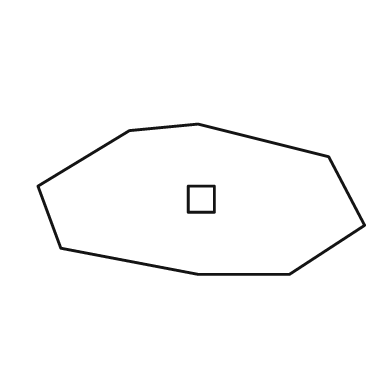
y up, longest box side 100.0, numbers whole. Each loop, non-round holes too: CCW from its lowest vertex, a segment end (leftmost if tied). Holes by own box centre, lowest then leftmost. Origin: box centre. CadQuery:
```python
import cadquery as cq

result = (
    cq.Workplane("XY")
    .moveTo(-1.0, -23.0)
    .lineTo(27.0, -23.0)
    .lineTo(50.0, -8.0)
    .lineTo(39.0, 13.0)
    .lineTo(-1.0, 23.0)
    .lineTo(-22.0, 21.0)
    .lineTo(-50.0, 4.0)
    .lineTo(-43.0, -15.0)
    .close()
    .moveTo(-4.0, -4.0)
    .lineTo(4.0, -4.0)
    .lineTo(4.0, 4.0)
    .lineTo(-4.0, 4.0)
    .close()
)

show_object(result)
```